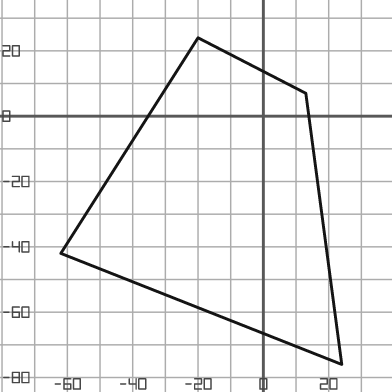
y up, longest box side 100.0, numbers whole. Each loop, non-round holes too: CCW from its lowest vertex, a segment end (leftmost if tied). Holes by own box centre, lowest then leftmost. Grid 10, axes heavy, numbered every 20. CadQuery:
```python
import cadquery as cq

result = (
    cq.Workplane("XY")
    .moveTo(24.0, -76.0)
    .lineTo(13.0, 7.0)
    .lineTo(-20.0, 24.0)
    .lineTo(-62.0, -42.0)
    .close()
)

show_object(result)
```